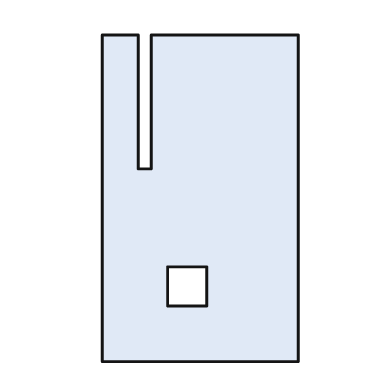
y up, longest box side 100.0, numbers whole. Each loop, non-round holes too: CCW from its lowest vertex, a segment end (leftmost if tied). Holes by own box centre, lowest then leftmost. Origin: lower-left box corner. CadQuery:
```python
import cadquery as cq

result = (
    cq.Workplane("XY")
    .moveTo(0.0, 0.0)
    .lineTo(60.0, 0.0)
    .lineTo(60.0, 100.0)
    .lineTo(15.0, 100.0)
    .lineTo(15.0, 59.0)
    .lineTo(11.0, 59.0)
    .lineTo(11.0, 100.0)
    .lineTo(0.0, 100.0)
    .close()
    .moveTo(20.0, 17.0)
    .lineTo(32.0, 17.0)
    .lineTo(32.0, 29.0)
    .lineTo(20.0, 29.0)
    .close()
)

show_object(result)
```